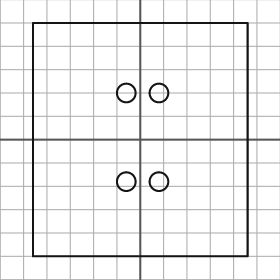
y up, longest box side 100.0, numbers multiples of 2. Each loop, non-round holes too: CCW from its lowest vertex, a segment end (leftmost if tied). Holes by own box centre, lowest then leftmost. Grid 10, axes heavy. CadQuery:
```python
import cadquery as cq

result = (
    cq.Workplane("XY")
    .moveTo(-46.0, -50.0)
    .lineTo(46.0, -50.0)
    .lineTo(46.0, 50.0)
    .lineTo(-46.0, 50.0)
    .close()
    .moveTo(-6.0, -18.0)
    .circle(4.0)
    .moveTo(8.0, -18.0)
    .circle(4.0)
    .moveTo(-6.0, 20.0)
    .circle(4.0)
    .moveTo(8.0, 20.0)
    .circle(4.0)
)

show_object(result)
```